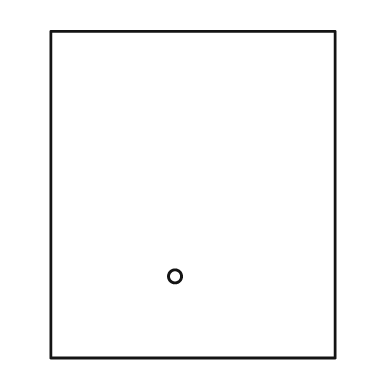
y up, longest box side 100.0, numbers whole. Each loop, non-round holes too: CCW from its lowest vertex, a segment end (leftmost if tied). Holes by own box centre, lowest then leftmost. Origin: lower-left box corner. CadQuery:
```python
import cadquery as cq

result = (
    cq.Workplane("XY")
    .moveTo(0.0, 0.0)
    .lineTo(87.0, 0.0)
    .lineTo(87.0, 100.0)
    .lineTo(0.0, 100.0)
    .close()
    .moveTo(38.0, 25.0)
    .circle(2.0)
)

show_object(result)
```